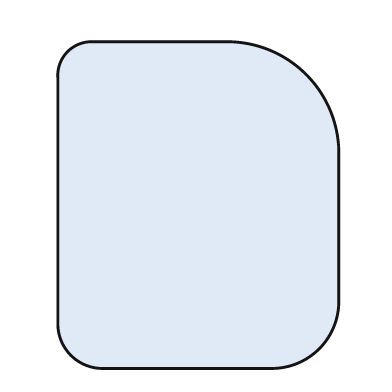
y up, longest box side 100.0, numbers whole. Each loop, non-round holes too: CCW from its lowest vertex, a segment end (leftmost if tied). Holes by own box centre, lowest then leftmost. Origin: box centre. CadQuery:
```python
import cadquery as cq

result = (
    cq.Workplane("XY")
    .moveTo(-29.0, -50.0)
    .lineTo(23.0, -50.0)
    .threePointArc((37.0, -44.0), (43.0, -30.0))
    .lineTo(43.0, 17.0)
    .threePointArc((33.0, 40.0), (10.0, 50.0))
    .lineTo(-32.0, 50.0)
    .threePointArc((-40.0, 47.0), (-43.0, 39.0))
    .lineTo(-43.0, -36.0)
    .threePointArc((-39.0, -46.0), (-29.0, -50.0))
    .close()
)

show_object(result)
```